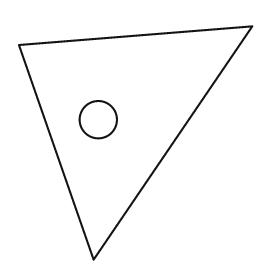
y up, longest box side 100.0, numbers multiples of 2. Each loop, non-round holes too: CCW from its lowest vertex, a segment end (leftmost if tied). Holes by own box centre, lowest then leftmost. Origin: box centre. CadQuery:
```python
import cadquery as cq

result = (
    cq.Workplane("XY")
    .moveTo(-18.0, -50.0)
    .lineTo(50.0, 50.0)
    .lineTo(-50.0, 42.0)
    .close()
    .moveTo(-16.0, 10.0)
    .circle(8.0)
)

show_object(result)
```